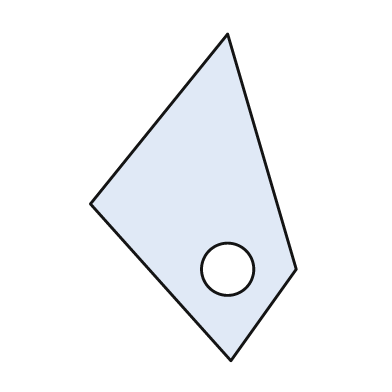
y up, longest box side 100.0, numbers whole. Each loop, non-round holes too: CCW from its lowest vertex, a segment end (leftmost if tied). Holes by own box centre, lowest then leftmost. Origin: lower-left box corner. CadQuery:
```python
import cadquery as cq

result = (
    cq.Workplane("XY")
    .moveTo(43.0, 0.0)
    .lineTo(63.0, 28.0)
    .lineTo(42.0, 100.0)
    .lineTo(0.0, 48.0)
    .close()
    .moveTo(42.0, 28.0)
    .circle(8.0)
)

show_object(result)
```